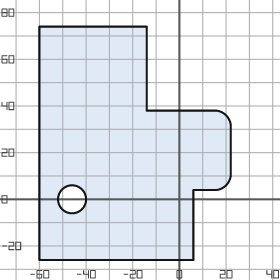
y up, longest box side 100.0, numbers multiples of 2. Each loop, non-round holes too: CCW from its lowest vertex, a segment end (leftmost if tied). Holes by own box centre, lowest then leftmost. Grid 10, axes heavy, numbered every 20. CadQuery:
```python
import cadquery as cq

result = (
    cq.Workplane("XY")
    .moveTo(-60.0, -26.0)
    .lineTo(6.0, -26.0)
    .lineTo(6.0, 4.0)
    .lineTo(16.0, 4.0)
    .threePointArc((20.0, 6.0), (22.0, 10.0))
    .lineTo(22.0, 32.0)
    .threePointArc((20.0, 36.0), (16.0, 38.0))
    .lineTo(-14.0, 38.0)
    .lineTo(-14.0, 74.0)
    .lineTo(-60.0, 74.0)
    .close()
    .moveTo(-46.0, 0.0)
    .circle(6.0)
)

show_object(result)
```